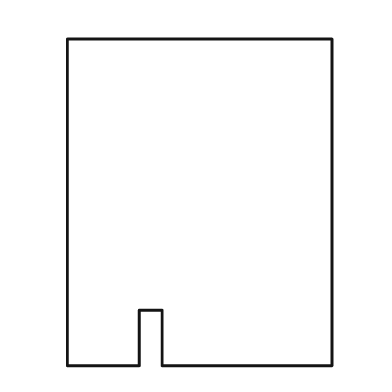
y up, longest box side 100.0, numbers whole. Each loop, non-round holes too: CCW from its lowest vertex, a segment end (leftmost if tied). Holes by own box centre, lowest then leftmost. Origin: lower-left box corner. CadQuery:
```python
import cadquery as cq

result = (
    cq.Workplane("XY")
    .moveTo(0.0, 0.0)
    .lineTo(22.0, 0.0)
    .lineTo(22.0, 17.0)
    .lineTo(29.0, 17.0)
    .lineTo(29.0, 0.0)
    .lineTo(81.0, 0.0)
    .lineTo(81.0, 100.0)
    .lineTo(0.0, 100.0)
    .close()
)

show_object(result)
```